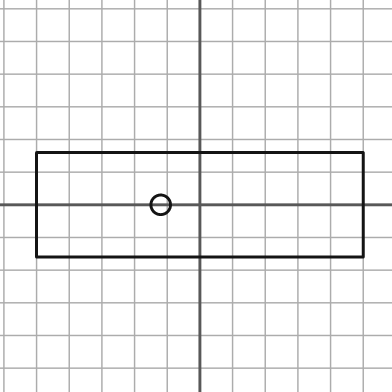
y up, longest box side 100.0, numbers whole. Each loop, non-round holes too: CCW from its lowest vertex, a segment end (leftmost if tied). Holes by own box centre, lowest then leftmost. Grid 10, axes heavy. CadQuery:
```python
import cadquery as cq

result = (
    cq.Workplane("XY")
    .moveTo(-50.0, -16.0)
    .lineTo(50.0, -16.0)
    .lineTo(50.0, 16.0)
    .lineTo(-50.0, 16.0)
    .close()
    .moveTo(-12.0, 0.0)
    .circle(3.0)
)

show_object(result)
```